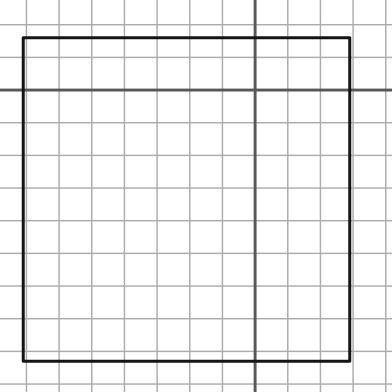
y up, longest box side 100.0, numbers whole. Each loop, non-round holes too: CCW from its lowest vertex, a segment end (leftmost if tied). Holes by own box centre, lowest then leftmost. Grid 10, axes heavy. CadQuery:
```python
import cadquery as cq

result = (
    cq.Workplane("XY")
    .moveTo(-71.0, -83.0)
    .lineTo(29.0, -83.0)
    .lineTo(29.0, 16.0)
    .lineTo(-71.0, 16.0)
    .close()
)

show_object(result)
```